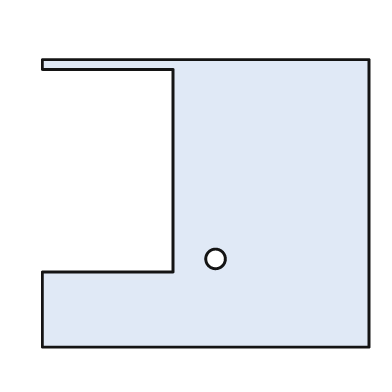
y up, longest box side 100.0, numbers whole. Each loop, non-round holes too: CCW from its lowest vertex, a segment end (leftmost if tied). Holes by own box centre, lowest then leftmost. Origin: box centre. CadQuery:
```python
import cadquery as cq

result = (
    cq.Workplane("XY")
    .moveTo(-50.0, -44.0)
    .lineTo(50.0, -44.0)
    .lineTo(50.0, 44.0)
    .lineTo(-50.0, 44.0)
    .lineTo(-50.0, 41.0)
    .lineTo(-10.0, 41.0)
    .lineTo(-10.0, -21.0)
    .lineTo(-50.0, -21.0)
    .close()
    .moveTo(3.0, -17.0)
    .circle(3.0)
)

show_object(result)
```